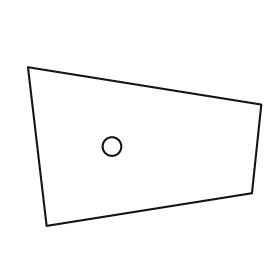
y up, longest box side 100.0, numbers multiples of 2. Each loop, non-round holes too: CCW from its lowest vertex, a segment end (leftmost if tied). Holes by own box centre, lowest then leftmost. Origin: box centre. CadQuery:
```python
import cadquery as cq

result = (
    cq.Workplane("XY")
    .moveTo(-42.0, -34.0)
    .lineTo(46.0, -20.0)
    .lineTo(50.0, 18.0)
    .lineTo(-50.0, 34.0)
    .close()
    .moveTo(-14.0, 0.0)
    .circle(4.0)
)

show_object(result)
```